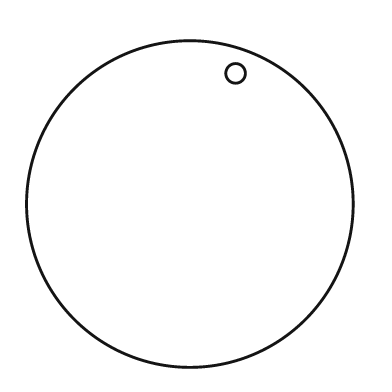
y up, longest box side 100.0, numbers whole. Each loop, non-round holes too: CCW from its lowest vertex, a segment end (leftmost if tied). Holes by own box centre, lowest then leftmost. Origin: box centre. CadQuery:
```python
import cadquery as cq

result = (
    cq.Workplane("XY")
    .moveTo(0.0, 0.0)
    .circle(50.0)
    .moveTo(14.0, 40.0)
    .circle(3.0)
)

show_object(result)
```